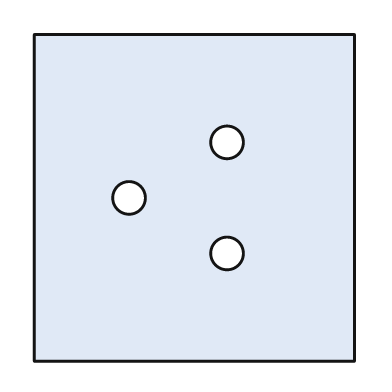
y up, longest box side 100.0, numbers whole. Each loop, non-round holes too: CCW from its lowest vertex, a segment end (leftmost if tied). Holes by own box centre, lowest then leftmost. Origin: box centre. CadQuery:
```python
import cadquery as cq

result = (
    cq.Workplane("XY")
    .moveTo(-49.0, -50.0)
    .lineTo(49.0, -50.0)
    .lineTo(49.0, 50.0)
    .lineTo(-49.0, 50.0)
    .close()
    .moveTo(10.0, -17.0)
    .circle(5.0)
    .moveTo(-20.0, 0.0)
    .circle(5.0)
    .moveTo(10.0, 17.0)
    .circle(5.0)
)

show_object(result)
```